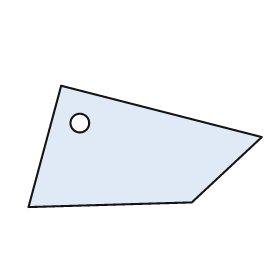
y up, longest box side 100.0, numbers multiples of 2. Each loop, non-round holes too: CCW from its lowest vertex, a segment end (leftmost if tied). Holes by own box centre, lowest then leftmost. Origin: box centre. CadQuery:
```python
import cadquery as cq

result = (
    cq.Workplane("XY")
    .moveTo(-50.0, -26.0)
    .lineTo(20.0, -24.0)
    .lineTo(50.0, 4.0)
    .lineTo(-36.0, 26.0)
    .close()
    .moveTo(-28.0, 10.0)
    .circle(4.0)
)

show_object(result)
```